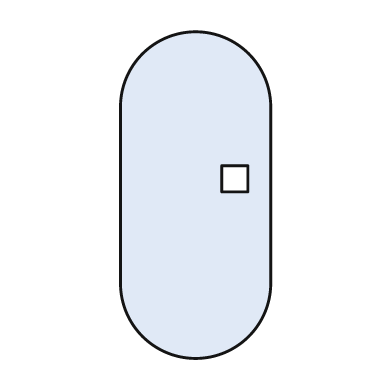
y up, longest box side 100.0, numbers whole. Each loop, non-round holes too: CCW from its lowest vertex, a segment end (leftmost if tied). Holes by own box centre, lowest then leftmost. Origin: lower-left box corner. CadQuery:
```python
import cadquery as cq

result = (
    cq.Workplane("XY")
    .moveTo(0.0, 23.0)
    .threePointArc((23.0, 0.0), (46.0, 23.0))
    .lineTo(46.0, 77.0)
    .threePointArc((23.0, 100.0), (0.0, 77.0))
    .close()
    .moveTo(31.0, 51.0)
    .lineTo(39.0, 51.0)
    .lineTo(39.0, 59.0)
    .lineTo(31.0, 59.0)
    .close()
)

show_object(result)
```